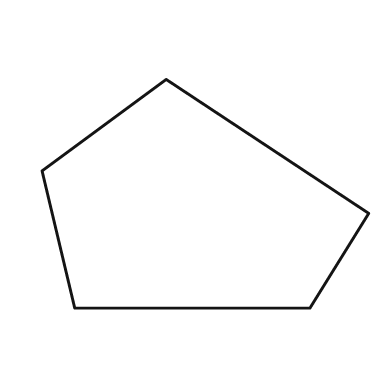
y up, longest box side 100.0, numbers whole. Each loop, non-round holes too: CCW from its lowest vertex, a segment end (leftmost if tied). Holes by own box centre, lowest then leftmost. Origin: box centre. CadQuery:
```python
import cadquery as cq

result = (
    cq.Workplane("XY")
    .moveTo(-40.0, -35.0)
    .lineTo(32.0, -35.0)
    .lineTo(50.0, -6.0)
    .lineTo(-12.0, 35.0)
    .lineTo(-50.0, 7.0)
    .close()
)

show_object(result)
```